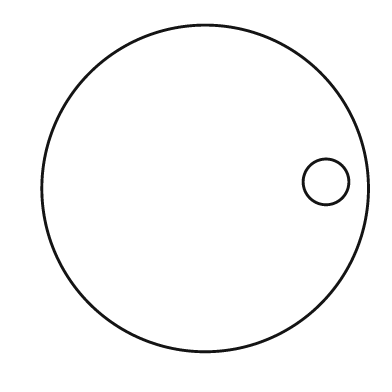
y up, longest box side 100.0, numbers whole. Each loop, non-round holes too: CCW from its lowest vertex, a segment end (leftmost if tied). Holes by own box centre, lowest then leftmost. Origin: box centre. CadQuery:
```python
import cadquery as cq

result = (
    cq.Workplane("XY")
    .moveTo(0.0, 0.0)
    .circle(50.0)
    .moveTo(37.0, 2.0)
    .circle(7.0)
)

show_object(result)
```